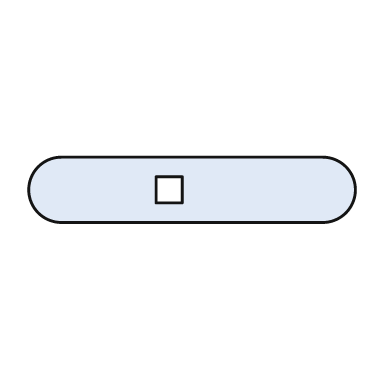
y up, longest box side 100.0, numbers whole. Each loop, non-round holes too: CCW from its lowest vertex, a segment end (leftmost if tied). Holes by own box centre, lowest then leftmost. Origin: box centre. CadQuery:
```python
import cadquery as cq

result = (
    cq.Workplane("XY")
    .moveTo(-40.0, -10.0)
    .lineTo(40.0, -10.0)
    .threePointArc((50.0, 0.0), (40.0, 10.0))
    .lineTo(-40.0, 10.0)
    .threePointArc((-50.0, 0.0), (-40.0, -10.0))
    .close()
    .moveTo(-11.0, -4.0)
    .lineTo(-3.0, -4.0)
    .lineTo(-3.0, 4.0)
    .lineTo(-11.0, 4.0)
    .close()
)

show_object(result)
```